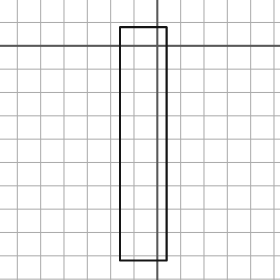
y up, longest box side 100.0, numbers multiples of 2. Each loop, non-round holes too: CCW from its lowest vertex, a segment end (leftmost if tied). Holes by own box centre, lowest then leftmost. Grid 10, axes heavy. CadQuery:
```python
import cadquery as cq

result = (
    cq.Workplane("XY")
    .moveTo(-16.0, -92.0)
    .lineTo(4.0, -92.0)
    .lineTo(4.0, 8.0)
    .lineTo(-16.0, 8.0)
    .close()
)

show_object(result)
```